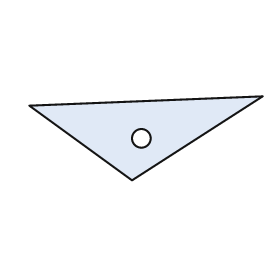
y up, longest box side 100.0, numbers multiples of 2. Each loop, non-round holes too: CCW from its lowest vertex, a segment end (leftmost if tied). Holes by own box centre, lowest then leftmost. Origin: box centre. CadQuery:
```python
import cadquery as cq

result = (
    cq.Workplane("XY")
    .moveTo(-6.0, -18.0)
    .lineTo(50.0, 18.0)
    .lineTo(-50.0, 14.0)
    .close()
    .moveTo(-2.0, 0.0)
    .circle(4.0)
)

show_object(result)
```